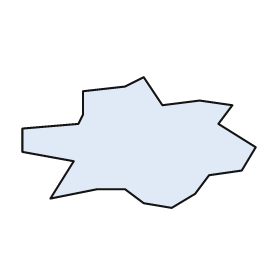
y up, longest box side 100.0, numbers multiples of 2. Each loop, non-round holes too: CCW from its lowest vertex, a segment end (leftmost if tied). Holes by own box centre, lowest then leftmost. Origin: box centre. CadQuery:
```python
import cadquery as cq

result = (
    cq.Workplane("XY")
    .moveTo(14.0, -28.0)
    .lineTo(24.0, -22.0)
    .lineTo(30.0, -14.0)
    .lineTo(44.0, -12.0)
    .lineTo(50.0, -2.0)
    .lineTo(34.0, 8.0)
    .lineTo(40.0, 16.0)
    .lineTo(26.0, 18.0)
    .lineTo(10.0, 16.0)
    .lineTo(2.0, 28.0)
    .lineTo(-6.0, 24.0)
    .lineTo(-24.0, 22.0)
    .lineTo(-24.0, 12.0)
    .lineTo(-26.0, 8.0)
    .lineTo(-50.0, 6.0)
    .lineTo(-50.0, -4.0)
    .lineTo(-28.0, -8.0)
    .lineTo(-38.0, -24.0)
    .lineTo(-18.0, -20.0)
    .lineTo(-6.0, -20.0)
    .lineTo(2.0, -26.0)
    .close()
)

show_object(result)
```